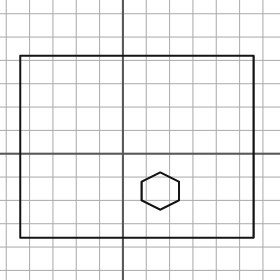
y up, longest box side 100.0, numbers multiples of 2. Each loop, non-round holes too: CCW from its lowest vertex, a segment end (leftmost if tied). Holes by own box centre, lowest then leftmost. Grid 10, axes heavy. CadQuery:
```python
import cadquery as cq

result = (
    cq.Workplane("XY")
    .moveTo(-44.0, -36.0)
    .lineTo(56.0, -36.0)
    .lineTo(56.0, 42.0)
    .lineTo(-44.0, 42.0)
    .close()
    .moveTo(16.0, -24.0)
    .lineTo(24.0, -20.0)
    .lineTo(24.0, -12.0)
    .lineTo(16.0, -8.0)
    .lineTo(8.0, -12.0)
    .lineTo(8.0, -20.0)
    .close()
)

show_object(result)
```